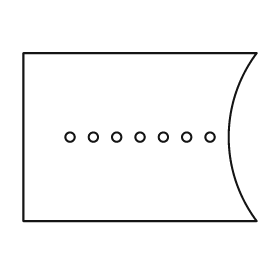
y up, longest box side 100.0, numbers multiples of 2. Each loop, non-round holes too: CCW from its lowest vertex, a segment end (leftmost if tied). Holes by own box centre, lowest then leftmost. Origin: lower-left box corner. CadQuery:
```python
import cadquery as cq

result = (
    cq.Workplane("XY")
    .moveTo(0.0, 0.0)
    .lineTo(100.0, 0.0)
    .threePointArc((88.0, 36.0), (100.0, 72.0))
    .lineTo(0.0, 72.0)
    .close()
    .moveTo(20.0, 36.0)
    .circle(2.0)
    .moveTo(30.0, 36.0)
    .circle(2.0)
    .moveTo(40.0, 36.0)
    .circle(2.0)
    .moveTo(50.0, 36.0)
    .circle(2.0)
    .moveTo(60.0, 36.0)
    .circle(2.0)
    .moveTo(70.0, 36.0)
    .circle(2.0)
    .moveTo(80.0, 36.0)
    .circle(2.0)
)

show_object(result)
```